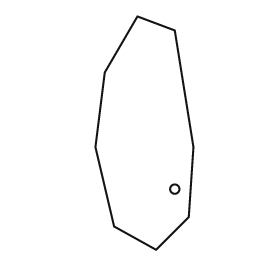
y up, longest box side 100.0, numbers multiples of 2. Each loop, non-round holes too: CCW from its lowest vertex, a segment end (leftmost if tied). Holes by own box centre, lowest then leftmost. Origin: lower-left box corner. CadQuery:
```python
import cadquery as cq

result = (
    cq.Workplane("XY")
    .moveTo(26.0, 0.0)
    .lineTo(40.0, 14.0)
    .lineTo(42.0, 44.0)
    .lineTo(34.0, 94.0)
    .lineTo(18.0, 100.0)
    .lineTo(4.0, 76.0)
    .lineTo(0.0, 44.0)
    .lineTo(8.0, 10.0)
    .close()
    .moveTo(34.0, 26.0)
    .circle(2.0)
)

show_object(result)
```